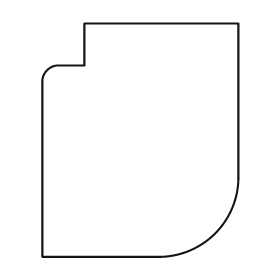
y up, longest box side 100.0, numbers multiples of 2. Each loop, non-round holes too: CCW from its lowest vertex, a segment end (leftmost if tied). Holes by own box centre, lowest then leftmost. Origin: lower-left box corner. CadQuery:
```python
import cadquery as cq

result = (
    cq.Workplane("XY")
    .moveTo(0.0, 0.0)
    .lineTo(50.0, 0.0)
    .threePointArc((74.0, 10.0), (84.0, 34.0))
    .lineTo(84.0, 100.0)
    .lineTo(18.0, 100.0)
    .lineTo(18.0, 82.0)
    .lineTo(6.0, 82.0)
    .threePointArc((2.0, 80.0), (0.0, 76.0))
    .close()
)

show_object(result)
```